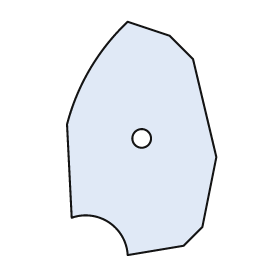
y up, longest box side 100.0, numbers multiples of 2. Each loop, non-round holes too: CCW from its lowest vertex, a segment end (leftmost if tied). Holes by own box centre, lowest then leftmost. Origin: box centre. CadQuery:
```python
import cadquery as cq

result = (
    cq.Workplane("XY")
    .moveTo(-6.0, -50.0)
    .lineTo(18.0, -46.0)
    .lineTo(26.0, -38.0)
    .lineTo(32.0, -8.0)
    .lineTo(22.0, 34.0)
    .lineTo(12.0, 44.0)
    .lineTo(-6.0, 50.0)
    .threePointArc((-22.0, 30.0), (-32.0, 6.0))
    .lineTo(-30.0, -34.0)
    .threePointArc((-14.0, -36.0), (-6.0, -50.0))
    .close()
    .moveTo(0.0, 0.0)
    .circle(4.0)
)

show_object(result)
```